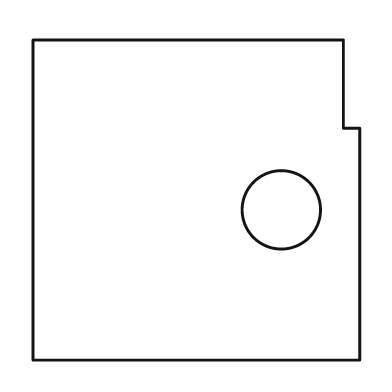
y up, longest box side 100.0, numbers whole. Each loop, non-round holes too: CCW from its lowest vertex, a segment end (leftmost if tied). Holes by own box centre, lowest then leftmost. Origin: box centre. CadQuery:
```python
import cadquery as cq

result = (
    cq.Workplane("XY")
    .moveTo(-50.0, -49.0)
    .lineTo(50.0, -49.0)
    .lineTo(50.0, 22.0)
    .lineTo(45.0, 22.0)
    .lineTo(45.0, 49.0)
    .lineTo(-50.0, 49.0)
    .close()
    .moveTo(26.0, -3.0)
    .circle(12.0)
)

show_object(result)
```